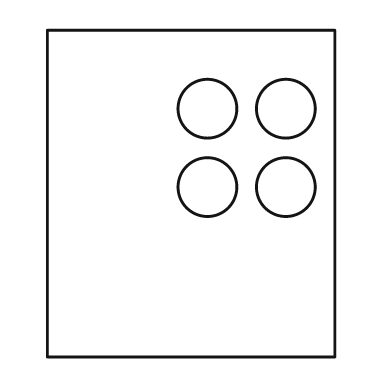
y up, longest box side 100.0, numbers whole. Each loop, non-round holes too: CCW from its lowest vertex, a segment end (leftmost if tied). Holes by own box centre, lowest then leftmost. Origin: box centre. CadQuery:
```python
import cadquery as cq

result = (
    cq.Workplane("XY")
    .moveTo(-44.0, -50.0)
    .lineTo(44.0, -50.0)
    .lineTo(44.0, 50.0)
    .lineTo(-44.0, 50.0)
    .close()
    .moveTo(5.0, 2.0)
    .circle(9.0)
    .moveTo(29.0, 2.0)
    .circle(9.0)
    .moveTo(5.0, 26.0)
    .circle(9.0)
    .moveTo(29.0, 26.0)
    .circle(9.0)
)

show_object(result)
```